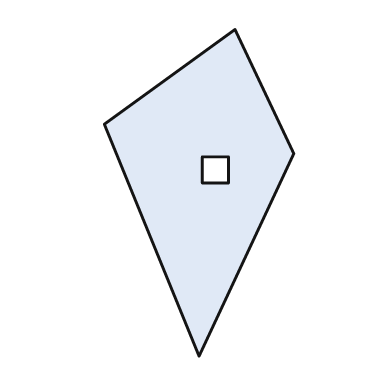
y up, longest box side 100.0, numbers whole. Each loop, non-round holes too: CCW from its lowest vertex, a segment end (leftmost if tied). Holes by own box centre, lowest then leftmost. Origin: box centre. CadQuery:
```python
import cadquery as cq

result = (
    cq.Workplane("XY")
    .moveTo(0.0, -50.0)
    .lineTo(29.0, 12.0)
    .lineTo(11.0, 50.0)
    .lineTo(-29.0, 21.0)
    .close()
    .moveTo(1.0, 3.0)
    .lineTo(9.0, 3.0)
    .lineTo(9.0, 11.0)
    .lineTo(1.0, 11.0)
    .close()
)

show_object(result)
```